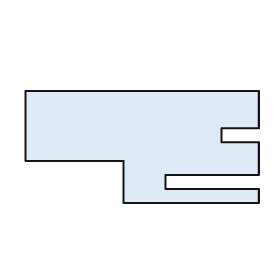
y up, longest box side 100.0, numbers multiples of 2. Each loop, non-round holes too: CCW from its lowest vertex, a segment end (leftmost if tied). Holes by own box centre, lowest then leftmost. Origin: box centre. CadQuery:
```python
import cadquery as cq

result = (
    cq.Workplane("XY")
    .moveTo(-8.0, -24.0)
    .lineTo(50.0, -24.0)
    .lineTo(50.0, -18.0)
    .lineTo(10.0, -18.0)
    .lineTo(10.0, -12.0)
    .lineTo(50.0, -12.0)
    .lineTo(50.0, 2.0)
    .lineTo(34.0, 2.0)
    .lineTo(34.0, 8.0)
    .lineTo(50.0, 8.0)
    .lineTo(50.0, 24.0)
    .lineTo(-50.0, 24.0)
    .lineTo(-50.0, -6.0)
    .lineTo(-8.0, -6.0)
    .close()
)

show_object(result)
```